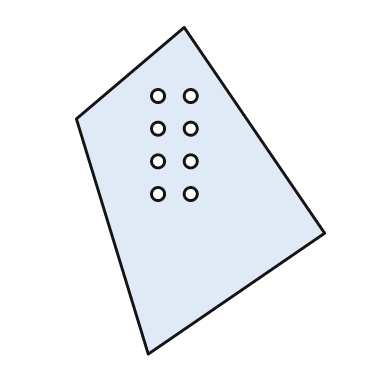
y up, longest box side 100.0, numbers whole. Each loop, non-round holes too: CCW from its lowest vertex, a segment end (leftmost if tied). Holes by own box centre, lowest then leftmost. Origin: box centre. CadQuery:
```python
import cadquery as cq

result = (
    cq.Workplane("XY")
    .moveTo(-16.0, -50.0)
    .lineTo(38.0, -13.0)
    .lineTo(-5.0, 50.0)
    .lineTo(-38.0, 22.0)
    .close()
    .moveTo(-13.0, -1.0)
    .circle(2.0)
    .moveTo(-3.0, -1.0)
    .circle(2.0)
    .moveTo(-13.0, 9.0)
    .circle(2.0)
    .moveTo(-3.0, 9.0)
    .circle(2.0)
    .moveTo(-13.0, 19.0)
    .circle(2.0)
    .moveTo(-3.0, 19.0)
    .circle(2.0)
    .moveTo(-13.0, 29.0)
    .circle(2.0)
    .moveTo(-3.0, 29.0)
    .circle(2.0)
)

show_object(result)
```